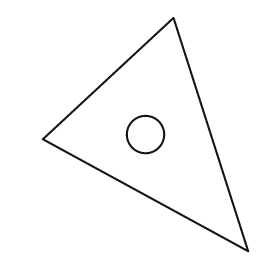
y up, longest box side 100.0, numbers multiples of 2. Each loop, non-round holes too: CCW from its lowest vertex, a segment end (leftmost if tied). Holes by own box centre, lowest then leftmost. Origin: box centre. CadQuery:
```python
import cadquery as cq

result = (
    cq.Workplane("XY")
    .moveTo(44.0, -50.0)
    .lineTo(12.0, 50.0)
    .lineTo(-44.0, -2.0)
    .close()
    .moveTo(0.0, 0.0)
    .circle(8.0)
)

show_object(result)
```